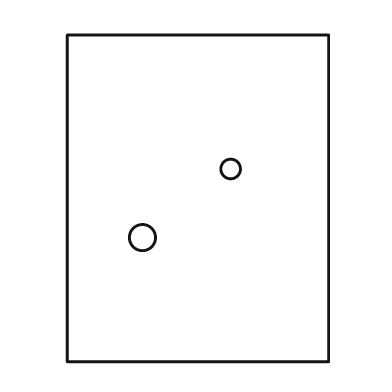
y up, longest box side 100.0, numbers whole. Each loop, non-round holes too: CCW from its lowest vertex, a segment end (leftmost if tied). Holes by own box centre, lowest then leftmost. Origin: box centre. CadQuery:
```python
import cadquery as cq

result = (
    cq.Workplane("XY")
    .moveTo(-40.0, -50.0)
    .lineTo(40.0, -50.0)
    .lineTo(40.0, 50.0)
    .lineTo(-40.0, 50.0)
    .close()
    .moveTo(-17.0, -12.0)
    .circle(4.0)
    .moveTo(10.0, 9.0)
    .circle(3.0)
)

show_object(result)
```